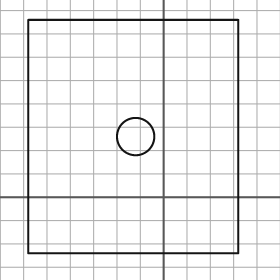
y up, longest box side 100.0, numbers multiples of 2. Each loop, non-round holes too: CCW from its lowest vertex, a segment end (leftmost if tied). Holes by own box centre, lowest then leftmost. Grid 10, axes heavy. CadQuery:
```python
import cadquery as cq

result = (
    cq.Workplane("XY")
    .moveTo(-58.0, -24.0)
    .lineTo(32.0, -24.0)
    .lineTo(32.0, 76.0)
    .lineTo(-58.0, 76.0)
    .close()
    .moveTo(-12.0, 26.0)
    .circle(8.0)
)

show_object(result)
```